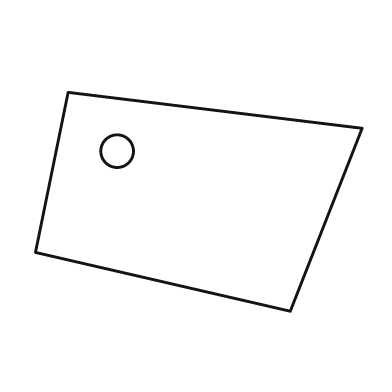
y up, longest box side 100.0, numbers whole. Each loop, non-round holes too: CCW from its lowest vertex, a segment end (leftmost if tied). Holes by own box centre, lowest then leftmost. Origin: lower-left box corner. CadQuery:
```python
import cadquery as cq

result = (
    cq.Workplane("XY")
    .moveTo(78.0, 0.0)
    .lineTo(100.0, 56.0)
    .lineTo(10.0, 67.0)
    .lineTo(0.0, 18.0)
    .close()
    .moveTo(25.0, 49.0)
    .circle(5.0)
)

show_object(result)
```